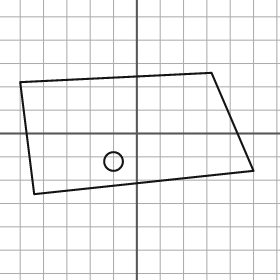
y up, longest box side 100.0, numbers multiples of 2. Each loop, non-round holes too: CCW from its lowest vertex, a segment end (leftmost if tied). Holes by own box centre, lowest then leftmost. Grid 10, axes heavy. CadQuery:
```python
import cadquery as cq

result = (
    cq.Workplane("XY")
    .moveTo(-44.0, -26.0)
    .lineTo(50.0, -16.0)
    .lineTo(32.0, 26.0)
    .lineTo(-50.0, 22.0)
    .close()
    .moveTo(-10.0, -12.0)
    .circle(4.0)
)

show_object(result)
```